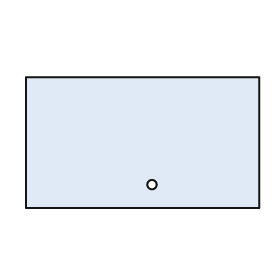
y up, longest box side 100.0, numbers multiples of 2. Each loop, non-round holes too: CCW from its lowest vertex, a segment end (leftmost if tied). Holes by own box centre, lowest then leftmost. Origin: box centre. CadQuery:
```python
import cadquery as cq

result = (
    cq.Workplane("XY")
    .moveTo(-50.0, -28.0)
    .lineTo(50.0, -28.0)
    .lineTo(50.0, 28.0)
    .lineTo(-50.0, 28.0)
    .close()
    .moveTo(4.0, -18.0)
    .circle(2.0)
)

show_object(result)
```